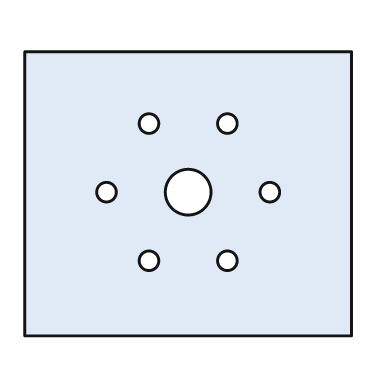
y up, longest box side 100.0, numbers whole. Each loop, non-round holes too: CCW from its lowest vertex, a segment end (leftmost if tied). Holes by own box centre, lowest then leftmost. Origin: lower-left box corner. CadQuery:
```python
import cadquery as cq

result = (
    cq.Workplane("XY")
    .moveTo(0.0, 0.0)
    .lineTo(100.0, 0.0)
    .lineTo(100.0, 87.0)
    .lineTo(0.0, 87.0)
    .close()
    .moveTo(38.0, 23.0)
    .circle(3.0)
    .moveTo(62.0, 23.0)
    .circle(3.0)
    .moveTo(25.0, 44.0)
    .circle(3.0)
    .moveTo(50.0, 44.0)
    .circle(7.0)
    .moveTo(75.0, 44.0)
    .circle(3.0)
    .moveTo(38.0, 65.0)
    .circle(3.0)
    .moveTo(62.0, 65.0)
    .circle(3.0)
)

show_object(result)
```